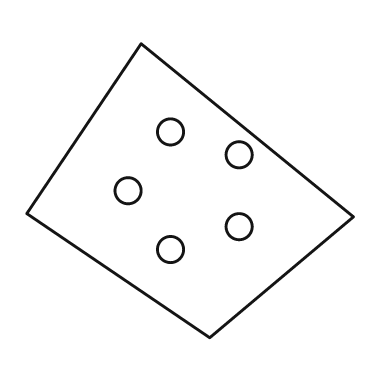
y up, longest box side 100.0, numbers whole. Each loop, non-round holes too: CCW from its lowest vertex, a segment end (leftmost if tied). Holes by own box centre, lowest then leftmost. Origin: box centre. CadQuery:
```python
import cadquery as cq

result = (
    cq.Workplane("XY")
    .moveTo(6.0, -45.0)
    .lineTo(50.0, -8.0)
    .lineTo(-15.0, 45.0)
    .lineTo(-50.0, -7.0)
    .close()
    .moveTo(-6.0, -18.0)
    .circle(4.0)
    .moveTo(15.0, -11.0)
    .circle(4.0)
    .moveTo(-19.0, 0.0)
    .circle(4.0)
    .moveTo(15.0, 11.0)
    .circle(4.0)
    .moveTo(-6.0, 18.0)
    .circle(4.0)
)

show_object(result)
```